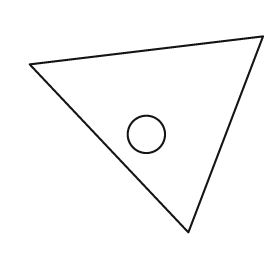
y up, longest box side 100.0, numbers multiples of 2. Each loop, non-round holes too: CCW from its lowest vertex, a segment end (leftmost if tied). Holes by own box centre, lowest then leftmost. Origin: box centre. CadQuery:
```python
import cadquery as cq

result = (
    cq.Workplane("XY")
    .moveTo(18.0, -42.0)
    .lineTo(50.0, 42.0)
    .lineTo(-50.0, 30.0)
    .close()
    .moveTo(0.0, 0.0)
    .circle(8.0)
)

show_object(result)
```